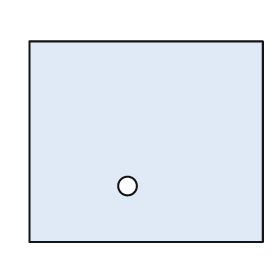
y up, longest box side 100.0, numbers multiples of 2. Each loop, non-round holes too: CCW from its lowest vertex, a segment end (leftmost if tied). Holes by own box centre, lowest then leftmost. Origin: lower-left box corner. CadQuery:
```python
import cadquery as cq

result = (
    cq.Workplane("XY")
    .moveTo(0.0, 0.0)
    .lineTo(100.0, 0.0)
    .lineTo(100.0, 86.0)
    .lineTo(0.0, 86.0)
    .close()
    .moveTo(42.0, 24.0)
    .circle(4.0)
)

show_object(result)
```